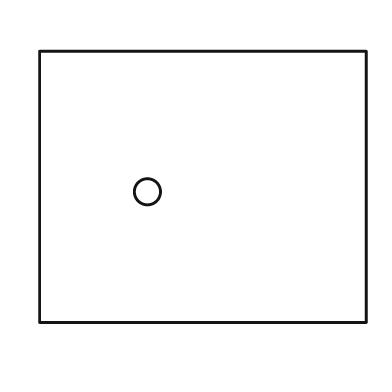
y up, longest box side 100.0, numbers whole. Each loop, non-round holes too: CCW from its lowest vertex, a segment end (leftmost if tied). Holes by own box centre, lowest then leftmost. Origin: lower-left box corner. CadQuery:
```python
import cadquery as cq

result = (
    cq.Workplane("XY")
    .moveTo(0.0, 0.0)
    .lineTo(100.0, 0.0)
    .lineTo(100.0, 83.0)
    .lineTo(0.0, 83.0)
    .close()
    .moveTo(33.0, 40.0)
    .circle(4.0)
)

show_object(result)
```